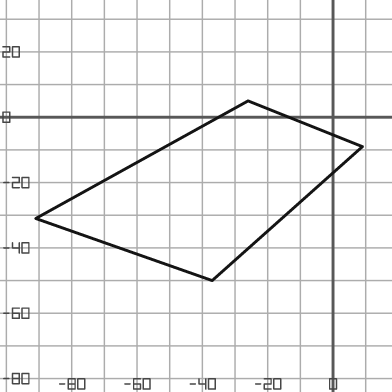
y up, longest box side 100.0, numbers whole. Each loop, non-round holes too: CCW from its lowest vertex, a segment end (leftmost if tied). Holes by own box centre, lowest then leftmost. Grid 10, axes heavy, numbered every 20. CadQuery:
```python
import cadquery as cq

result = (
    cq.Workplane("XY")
    .moveTo(-37.0, -50.0)
    .lineTo(9.0, -9.0)
    .lineTo(-26.0, 5.0)
    .lineTo(-91.0, -31.0)
    .close()
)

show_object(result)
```